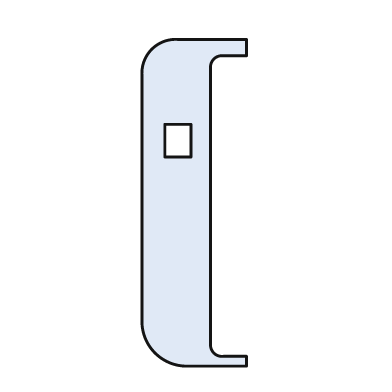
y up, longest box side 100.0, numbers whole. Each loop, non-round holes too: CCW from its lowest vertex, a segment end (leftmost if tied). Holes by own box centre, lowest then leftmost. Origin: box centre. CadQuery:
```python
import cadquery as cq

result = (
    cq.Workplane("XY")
    .moveTo(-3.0, -50.0)
    .lineTo(16.0, -50.0)
    .lineTo(16.0, -47.0)
    .lineTo(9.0, -47.0)
    .threePointArc((6.0, -46.0), (5.0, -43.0))
    .lineTo(5.0, 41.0)
    .threePointArc((6.0, 44.0), (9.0, 45.0))
    .lineTo(16.0, 45.0)
    .lineTo(16.0, 50.0)
    .lineTo(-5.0, 50.0)
    .threePointArc((-13.0, 47.0), (-16.0, 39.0))
    .lineTo(-16.0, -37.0)
    .threePointArc((-12.0, -46.0), (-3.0, -50.0))
    .close()
    .moveTo(-9.0, 14.0)
    .lineTo(-1.0, 14.0)
    .lineTo(-1.0, 24.0)
    .lineTo(-9.0, 24.0)
    .close()
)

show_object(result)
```